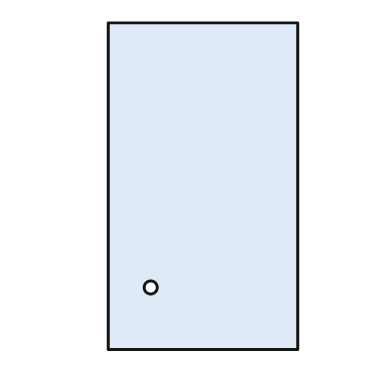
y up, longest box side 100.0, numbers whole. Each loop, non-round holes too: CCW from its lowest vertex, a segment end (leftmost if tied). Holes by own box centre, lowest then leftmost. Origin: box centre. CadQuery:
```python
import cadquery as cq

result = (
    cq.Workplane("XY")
    .moveTo(-29.0, -50.0)
    .lineTo(29.0, -50.0)
    .lineTo(29.0, 50.0)
    .lineTo(-29.0, 50.0)
    .close()
    .moveTo(-16.0, -31.0)
    .circle(2.0)
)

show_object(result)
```